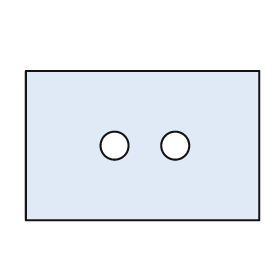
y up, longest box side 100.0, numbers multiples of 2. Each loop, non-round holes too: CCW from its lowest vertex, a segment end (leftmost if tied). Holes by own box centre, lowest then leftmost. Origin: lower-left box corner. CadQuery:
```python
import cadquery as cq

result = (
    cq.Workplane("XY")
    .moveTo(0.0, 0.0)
    .lineTo(100.0, 0.0)
    .lineTo(100.0, 64.0)
    .lineTo(0.0, 64.0)
    .close()
    .moveTo(38.0, 32.0)
    .circle(6.0)
    .moveTo(64.0, 32.0)
    .circle(6.0)
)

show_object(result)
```